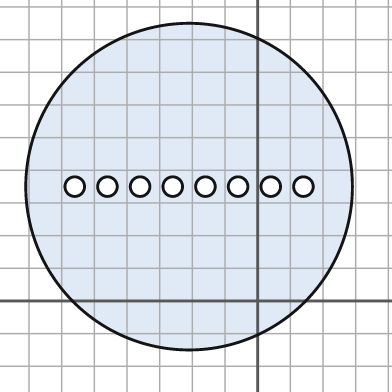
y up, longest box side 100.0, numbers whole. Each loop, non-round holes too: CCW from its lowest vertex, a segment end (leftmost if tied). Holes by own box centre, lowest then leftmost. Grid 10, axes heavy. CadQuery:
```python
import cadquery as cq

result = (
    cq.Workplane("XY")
    .moveTo(-21.0, 35.0)
    .circle(50.0)
    .moveTo(-56.0, 35.0)
    .circle(3.0)
    .moveTo(-46.0, 35.0)
    .circle(3.0)
    .moveTo(-36.0, 35.0)
    .circle(3.0)
    .moveTo(-26.0, 35.0)
    .circle(3.0)
    .moveTo(-16.0, 35.0)
    .circle(3.0)
    .moveTo(-6.0, 35.0)
    .circle(3.0)
    .moveTo(4.0, 35.0)
    .circle(3.0)
    .moveTo(14.0, 35.0)
    .circle(3.0)
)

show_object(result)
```